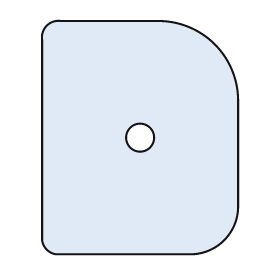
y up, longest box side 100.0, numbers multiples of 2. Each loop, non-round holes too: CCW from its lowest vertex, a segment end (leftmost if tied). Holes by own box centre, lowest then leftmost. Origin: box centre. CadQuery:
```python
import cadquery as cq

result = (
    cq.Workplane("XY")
    .moveTo(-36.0, -50.0)
    .lineTo(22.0, -50.0)
    .threePointArc((36.0, -44.0), (42.0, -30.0))
    .lineTo(42.0, 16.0)
    .threePointArc((32.0, 40.0), (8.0, 50.0))
    .lineTo(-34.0, 50.0)
    .threePointArc((-40.0, 48.0), (-42.0, 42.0))
    .lineTo(-42.0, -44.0)
    .threePointArc((-40.0, -48.0), (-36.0, -50.0))
    .close()
    .moveTo(0.0, 0.0)
    .circle(6.0)
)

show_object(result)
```